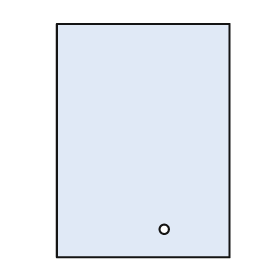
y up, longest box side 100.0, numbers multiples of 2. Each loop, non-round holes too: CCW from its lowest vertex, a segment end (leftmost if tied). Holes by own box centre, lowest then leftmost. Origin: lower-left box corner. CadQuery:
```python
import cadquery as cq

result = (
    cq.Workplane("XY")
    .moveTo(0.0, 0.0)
    .lineTo(74.0, 0.0)
    .lineTo(74.0, 100.0)
    .lineTo(0.0, 100.0)
    .close()
    .moveTo(46.0, 12.0)
    .circle(2.0)
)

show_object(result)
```